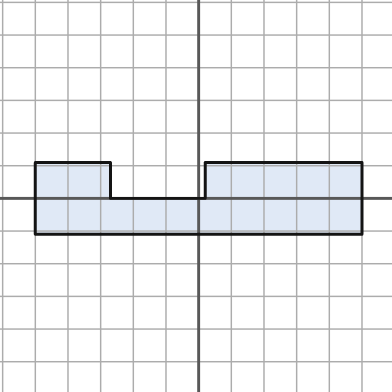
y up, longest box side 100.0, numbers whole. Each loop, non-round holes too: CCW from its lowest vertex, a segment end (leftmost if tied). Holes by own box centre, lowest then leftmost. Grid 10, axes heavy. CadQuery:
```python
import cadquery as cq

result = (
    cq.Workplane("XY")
    .moveTo(-50.0, -11.0)
    .lineTo(50.0, -11.0)
    .lineTo(50.0, 11.0)
    .lineTo(2.0, 11.0)
    .lineTo(2.0, 0.0)
    .lineTo(-27.0, 0.0)
    .lineTo(-27.0, 11.0)
    .lineTo(-50.0, 11.0)
    .close()
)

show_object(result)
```